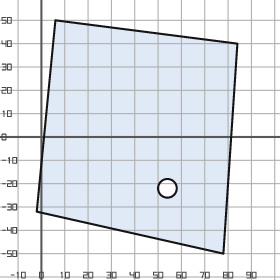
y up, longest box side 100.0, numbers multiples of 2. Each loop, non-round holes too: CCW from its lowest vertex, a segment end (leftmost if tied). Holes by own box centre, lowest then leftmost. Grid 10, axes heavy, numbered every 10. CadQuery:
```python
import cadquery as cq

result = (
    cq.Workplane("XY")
    .moveTo(78.0, -50.0)
    .lineTo(84.0, 40.0)
    .lineTo(6.0, 50.0)
    .lineTo(-2.0, -32.0)
    .close()
    .moveTo(54.0, -22.0)
    .circle(4.0)
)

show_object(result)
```